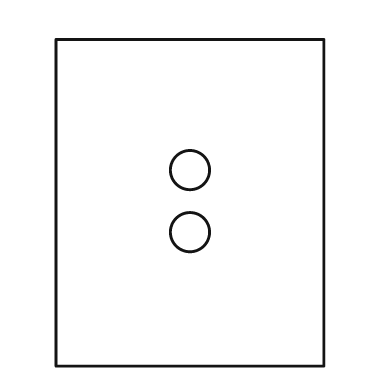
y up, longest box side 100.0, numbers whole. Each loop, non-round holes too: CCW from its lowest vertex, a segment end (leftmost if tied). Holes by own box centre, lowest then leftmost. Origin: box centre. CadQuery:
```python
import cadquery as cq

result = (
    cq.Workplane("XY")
    .moveTo(-41.0, -50.0)
    .lineTo(41.0, -50.0)
    .lineTo(41.0, 50.0)
    .lineTo(-41.0, 50.0)
    .close()
    .moveTo(0.0, -9.0)
    .circle(6.0)
    .moveTo(0.0, 10.0)
    .circle(6.0)
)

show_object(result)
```